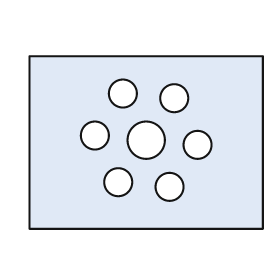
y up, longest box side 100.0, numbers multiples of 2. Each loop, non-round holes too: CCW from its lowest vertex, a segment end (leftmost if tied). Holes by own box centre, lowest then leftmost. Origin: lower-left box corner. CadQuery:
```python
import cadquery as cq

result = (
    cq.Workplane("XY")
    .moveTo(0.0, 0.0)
    .lineTo(100.0, 0.0)
    .lineTo(100.0, 74.0)
    .lineTo(0.0, 74.0)
    .close()
    .moveTo(60.0, 18.0)
    .circle(6.0)
    .moveTo(38.0, 20.0)
    .circle(6.0)
    .moveTo(72.0, 36.0)
    .circle(6.0)
    .moveTo(50.0, 38.0)
    .circle(8.0)
    .moveTo(28.0, 40.0)
    .circle(6.0)
    .moveTo(62.0, 56.0)
    .circle(6.0)
    .moveTo(40.0, 58.0)
    .circle(6.0)
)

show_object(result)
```